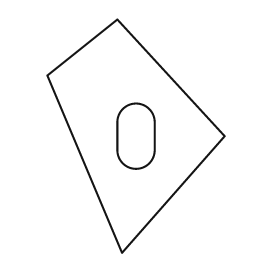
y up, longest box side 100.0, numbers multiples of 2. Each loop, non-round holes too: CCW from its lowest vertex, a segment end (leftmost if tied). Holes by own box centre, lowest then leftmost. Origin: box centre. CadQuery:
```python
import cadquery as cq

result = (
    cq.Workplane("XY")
    .moveTo(-6.0, -50.0)
    .lineTo(38.0, 0.0)
    .lineTo(-8.0, 50.0)
    .lineTo(-38.0, 26.0)
    .close()
    .moveTo(-8.0, -6.0)
    .threePointArc((0.0, -14.0), (8.0, -6.0))
    .lineTo(8.0, 6.0)
    .threePointArc((0.0, 14.0), (-8.0, 6.0))
    .close()
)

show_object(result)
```